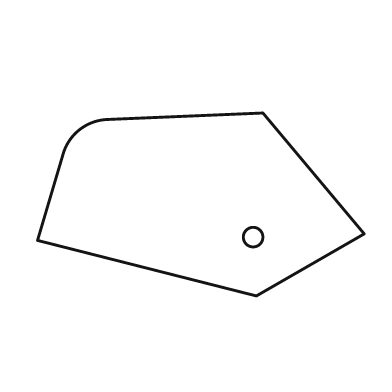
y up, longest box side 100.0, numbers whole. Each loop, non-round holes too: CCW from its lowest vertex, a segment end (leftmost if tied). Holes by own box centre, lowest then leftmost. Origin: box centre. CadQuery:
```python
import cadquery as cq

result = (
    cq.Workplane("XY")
    .moveTo(17.0, -28.0)
    .lineTo(50.0, -9.0)
    .lineTo(19.0, 28.0)
    .lineTo(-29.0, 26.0)
    .threePointArc((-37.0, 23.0), (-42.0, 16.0))
    .lineTo(-50.0, -11.0)
    .close()
    .moveTo(16.0, -10.0)
    .circle(3.0)
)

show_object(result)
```